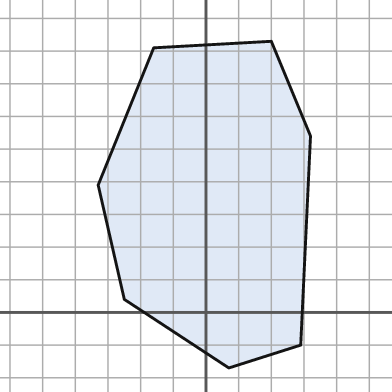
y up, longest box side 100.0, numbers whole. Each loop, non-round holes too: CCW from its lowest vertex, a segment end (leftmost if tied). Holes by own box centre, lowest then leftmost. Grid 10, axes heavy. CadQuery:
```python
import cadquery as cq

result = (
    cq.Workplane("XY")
    .moveTo(7.0, -17.0)
    .lineTo(29.0, -10.0)
    .lineTo(32.0, 54.0)
    .lineTo(20.0, 83.0)
    .lineTo(-16.0, 81.0)
    .lineTo(-33.0, 39.0)
    .lineTo(-25.0, 4.0)
    .close()
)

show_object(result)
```